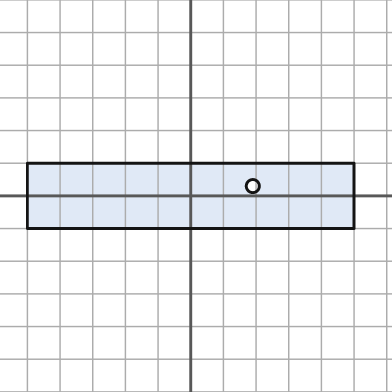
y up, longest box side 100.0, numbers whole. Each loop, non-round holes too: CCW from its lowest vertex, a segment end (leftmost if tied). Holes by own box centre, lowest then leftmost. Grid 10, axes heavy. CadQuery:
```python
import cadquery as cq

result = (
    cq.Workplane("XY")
    .moveTo(-50.0, -10.0)
    .lineTo(50.0, -10.0)
    .lineTo(50.0, 10.0)
    .lineTo(-50.0, 10.0)
    .close()
    .moveTo(19.0, 3.0)
    .circle(2.0)
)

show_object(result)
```